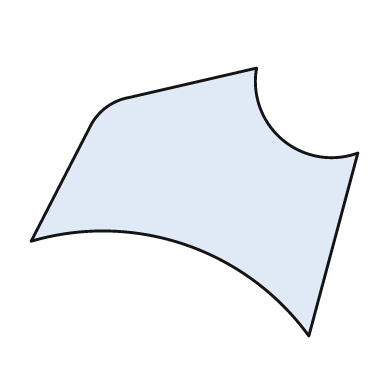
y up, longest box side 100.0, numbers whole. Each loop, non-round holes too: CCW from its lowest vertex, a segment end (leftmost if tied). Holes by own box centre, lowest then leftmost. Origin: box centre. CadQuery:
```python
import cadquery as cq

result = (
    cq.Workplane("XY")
    .moveTo(35.0, -41.0)
    .lineTo(50.0, 15.0)
    .threePointArc((27.0, 19.0), (19.0, 41.0))
    .lineTo(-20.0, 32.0)
    .threePointArc((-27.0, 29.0), (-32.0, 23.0))
    .lineTo(-50.0, -12.0)
    .threePointArc((-3.0, -13.0), (35.0, -41.0))
    .close()
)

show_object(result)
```